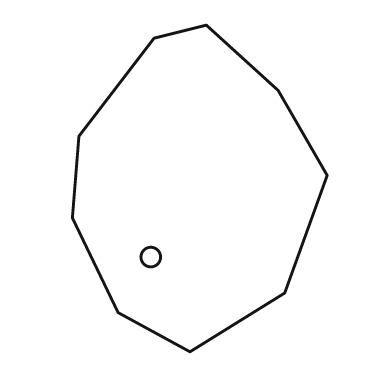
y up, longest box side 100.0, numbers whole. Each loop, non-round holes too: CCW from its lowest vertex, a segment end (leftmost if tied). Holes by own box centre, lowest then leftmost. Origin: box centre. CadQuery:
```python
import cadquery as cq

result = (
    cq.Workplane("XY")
    .moveTo(-3.0, -50.0)
    .lineTo(26.0, -32.0)
    .lineTo(39.0, 4.0)
    .lineTo(24.0, 30.0)
    .lineTo(2.0, 50.0)
    .lineTo(-14.0, 46.0)
    .lineTo(-37.0, 16.0)
    .lineTo(-39.0, -9.0)
    .lineTo(-25.0, -38.0)
    .close()
    .moveTo(-15.0, -21.0)
    .circle(3.0)
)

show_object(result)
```